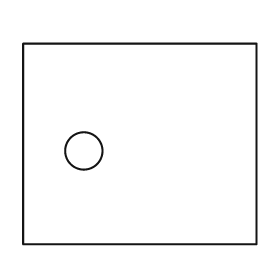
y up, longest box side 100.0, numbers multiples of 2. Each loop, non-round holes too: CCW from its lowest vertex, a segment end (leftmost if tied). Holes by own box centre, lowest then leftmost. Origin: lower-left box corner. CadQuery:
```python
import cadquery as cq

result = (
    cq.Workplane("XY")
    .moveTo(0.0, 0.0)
    .lineTo(100.0, 0.0)
    .lineTo(100.0, 86.0)
    .lineTo(0.0, 86.0)
    .close()
    .moveTo(26.0, 40.0)
    .circle(8.0)
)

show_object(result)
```